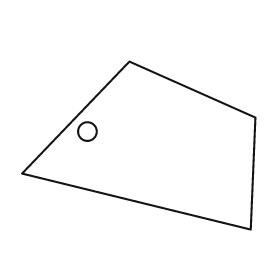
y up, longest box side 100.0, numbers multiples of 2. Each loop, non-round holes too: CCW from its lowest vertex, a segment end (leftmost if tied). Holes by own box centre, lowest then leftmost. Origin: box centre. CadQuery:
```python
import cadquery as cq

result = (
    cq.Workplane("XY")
    .moveTo(48.0, -36.0)
    .lineTo(50.0, 12.0)
    .lineTo(-4.0, 36.0)
    .lineTo(-50.0, -12.0)
    .close()
    .moveTo(-22.0, 6.0)
    .circle(4.0)
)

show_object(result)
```